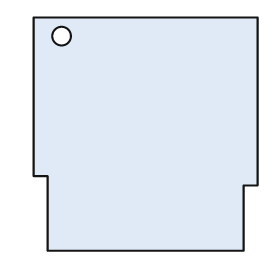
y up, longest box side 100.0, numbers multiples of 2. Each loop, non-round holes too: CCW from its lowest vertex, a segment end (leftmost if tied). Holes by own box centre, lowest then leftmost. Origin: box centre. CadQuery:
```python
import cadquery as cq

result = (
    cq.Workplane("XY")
    .moveTo(-42.0, -50.0)
    .lineTo(42.0, -50.0)
    .lineTo(42.0, -22.0)
    .lineTo(48.0, -22.0)
    .lineTo(48.0, 50.0)
    .lineTo(-48.0, 50.0)
    .lineTo(-48.0, -18.0)
    .lineTo(-42.0, -18.0)
    .close()
    .moveTo(-36.0, 42.0)
    .circle(4.0)
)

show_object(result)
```